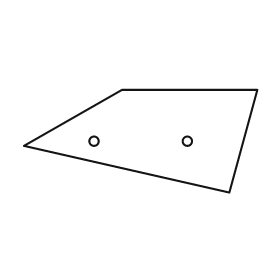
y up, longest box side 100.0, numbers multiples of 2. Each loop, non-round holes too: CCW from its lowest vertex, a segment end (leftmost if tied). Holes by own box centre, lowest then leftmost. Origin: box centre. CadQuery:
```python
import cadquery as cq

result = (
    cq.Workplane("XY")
    .moveTo(38.0, -22.0)
    .lineTo(50.0, 22.0)
    .lineTo(-8.0, 22.0)
    .lineTo(-50.0, -2.0)
    .close()
    .moveTo(-20.0, 0.0)
    .circle(2.0)
    .moveTo(20.0, 0.0)
    .circle(2.0)
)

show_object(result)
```